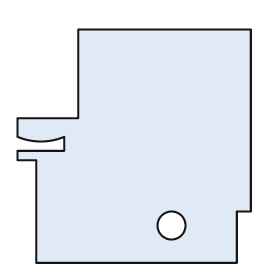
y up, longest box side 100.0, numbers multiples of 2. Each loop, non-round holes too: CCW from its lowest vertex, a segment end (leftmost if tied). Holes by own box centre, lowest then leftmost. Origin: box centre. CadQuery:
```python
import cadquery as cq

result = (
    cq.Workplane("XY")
    .moveTo(-42.0, -50.0)
    .lineTo(44.0, -50.0)
    .lineTo(44.0, -28.0)
    .lineTo(50.0, -28.0)
    .lineTo(50.0, 50.0)
    .lineTo(-24.0, 50.0)
    .lineTo(-24.0, 12.0)
    .lineTo(-50.0, 12.0)
    .lineTo(-50.0, 4.0)
    .threePointArc((-40.0, 2.0), (-30.0, 4.0))
    .lineTo(-30.0, -2.0)
    .lineTo(-50.0, -2.0)
    .lineTo(-50.0, -6.0)
    .lineTo(-42.0, -6.0)
    .close()
    .moveTo(16.0, -34.0)
    .circle(6.0)
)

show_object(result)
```